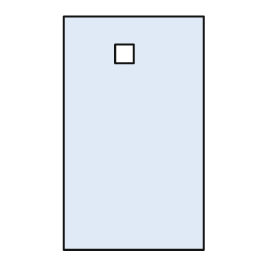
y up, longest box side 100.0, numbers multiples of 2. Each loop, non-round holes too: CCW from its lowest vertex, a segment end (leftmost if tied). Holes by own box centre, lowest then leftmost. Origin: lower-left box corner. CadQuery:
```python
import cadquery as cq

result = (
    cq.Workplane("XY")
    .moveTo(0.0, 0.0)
    .lineTo(60.0, 0.0)
    .lineTo(60.0, 100.0)
    .lineTo(0.0, 100.0)
    .close()
    .moveTo(22.0, 80.0)
    .lineTo(30.0, 80.0)
    .lineTo(30.0, 88.0)
    .lineTo(22.0, 88.0)
    .close()
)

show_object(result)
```